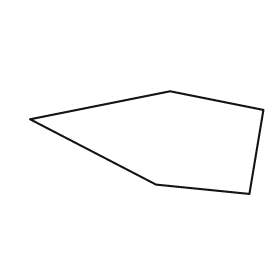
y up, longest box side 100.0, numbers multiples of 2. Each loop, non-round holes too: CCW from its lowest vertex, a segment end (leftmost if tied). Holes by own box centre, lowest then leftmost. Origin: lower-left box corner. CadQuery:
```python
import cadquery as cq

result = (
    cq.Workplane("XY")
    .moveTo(94.0, 0.0)
    .lineTo(100.0, 36.0)
    .lineTo(60.0, 44.0)
    .lineTo(0.0, 32.0)
    .lineTo(54.0, 4.0)
    .close()
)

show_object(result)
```